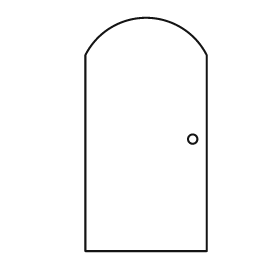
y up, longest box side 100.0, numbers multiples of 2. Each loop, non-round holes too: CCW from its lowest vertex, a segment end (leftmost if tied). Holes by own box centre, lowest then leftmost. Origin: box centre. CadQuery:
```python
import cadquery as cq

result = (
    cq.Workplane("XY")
    .moveTo(-26.0, -50.0)
    .lineTo(26.0, -50.0)
    .lineTo(26.0, 34.0)
    .threePointArc((0.0, 50.0), (-26.0, 34.0))
    .close()
    .moveTo(20.0, -2.0)
    .circle(2.0)
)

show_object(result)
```